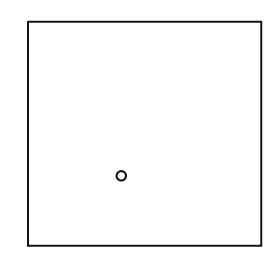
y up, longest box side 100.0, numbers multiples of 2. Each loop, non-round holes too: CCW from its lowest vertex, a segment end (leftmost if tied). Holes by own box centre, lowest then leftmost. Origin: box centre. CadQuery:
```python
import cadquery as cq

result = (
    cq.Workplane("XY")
    .moveTo(-50.0, -48.0)
    .lineTo(50.0, -48.0)
    .lineTo(50.0, 48.0)
    .lineTo(-50.0, 48.0)
    .close()
    .moveTo(-10.0, -18.0)
    .circle(2.0)
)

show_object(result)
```